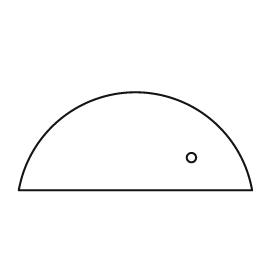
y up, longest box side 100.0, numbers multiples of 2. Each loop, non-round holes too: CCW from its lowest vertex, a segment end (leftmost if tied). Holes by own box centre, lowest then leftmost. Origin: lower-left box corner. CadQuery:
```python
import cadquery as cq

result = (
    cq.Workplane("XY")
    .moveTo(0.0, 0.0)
    .lineTo(100.0, 0.0)
    .threePointArc((50.0, 42.0), (0.0, 0.0))
    .close()
    .moveTo(74.0, 14.0)
    .circle(2.0)
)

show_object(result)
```